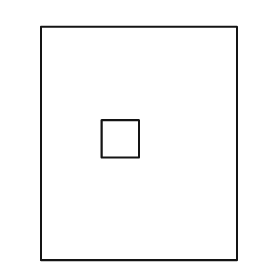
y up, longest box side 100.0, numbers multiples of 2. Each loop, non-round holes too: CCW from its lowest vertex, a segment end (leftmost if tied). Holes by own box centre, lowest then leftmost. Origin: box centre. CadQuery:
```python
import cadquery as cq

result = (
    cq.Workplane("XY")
    .moveTo(-42.0, -50.0)
    .lineTo(42.0, -50.0)
    .lineTo(42.0, 50.0)
    .lineTo(-42.0, 50.0)
    .close()
    .moveTo(-16.0, -6.0)
    .lineTo(0.0, -6.0)
    .lineTo(0.0, 10.0)
    .lineTo(-16.0, 10.0)
    .close()
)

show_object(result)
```